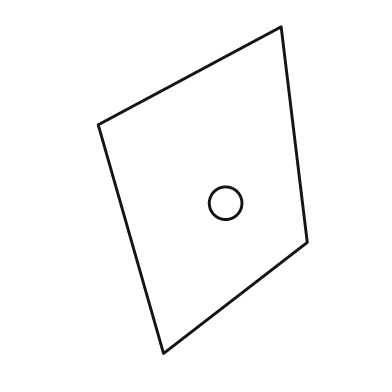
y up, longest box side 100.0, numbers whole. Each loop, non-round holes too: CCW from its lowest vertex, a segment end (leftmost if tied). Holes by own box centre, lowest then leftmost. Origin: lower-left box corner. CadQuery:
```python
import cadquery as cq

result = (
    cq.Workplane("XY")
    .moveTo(20.0, 0.0)
    .lineTo(64.0, 34.0)
    .lineTo(56.0, 100.0)
    .lineTo(0.0, 70.0)
    .close()
    .moveTo(39.0, 46.0)
    .circle(5.0)
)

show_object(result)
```